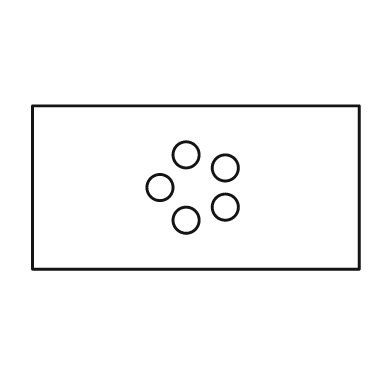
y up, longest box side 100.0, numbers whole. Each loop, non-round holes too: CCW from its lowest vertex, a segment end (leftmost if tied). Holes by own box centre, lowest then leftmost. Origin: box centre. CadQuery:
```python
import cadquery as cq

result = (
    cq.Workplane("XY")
    .moveTo(-50.0, -25.0)
    .lineTo(50.0, -25.0)
    .lineTo(50.0, 25.0)
    .lineTo(-50.0, 25.0)
    .close()
    .moveTo(-3.0, -10.0)
    .circle(4.0)
    .moveTo(9.0, -6.0)
    .circle(4.0)
    .moveTo(-11.0, 0.0)
    .circle(4.0)
    .moveTo(9.0, 6.0)
    .circle(4.0)
    .moveTo(-3.0, 10.0)
    .circle(4.0)
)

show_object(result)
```